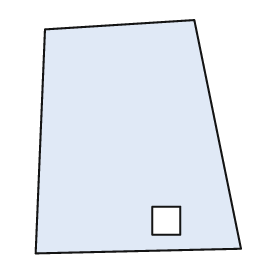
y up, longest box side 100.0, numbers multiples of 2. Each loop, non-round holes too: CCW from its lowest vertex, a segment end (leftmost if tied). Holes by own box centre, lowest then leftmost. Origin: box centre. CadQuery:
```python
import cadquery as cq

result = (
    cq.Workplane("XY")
    .moveTo(-44.0, -50.0)
    .lineTo(44.0, -48.0)
    .lineTo(24.0, 50.0)
    .lineTo(-40.0, 46.0)
    .close()
    .moveTo(6.0, -42.0)
    .lineTo(18.0, -42.0)
    .lineTo(18.0, -30.0)
    .lineTo(6.0, -30.0)
    .close()
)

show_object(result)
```